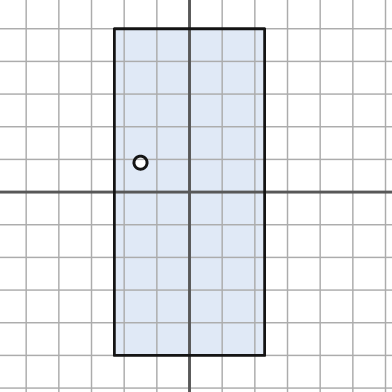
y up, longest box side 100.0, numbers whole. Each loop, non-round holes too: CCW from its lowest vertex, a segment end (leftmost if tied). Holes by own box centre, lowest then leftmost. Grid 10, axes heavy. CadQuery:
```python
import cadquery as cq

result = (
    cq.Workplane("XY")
    .moveTo(-23.0, -50.0)
    .lineTo(23.0, -50.0)
    .lineTo(23.0, 50.0)
    .lineTo(-23.0, 50.0)
    .close()
    .moveTo(-15.0, 9.0)
    .circle(2.0)
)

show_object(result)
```